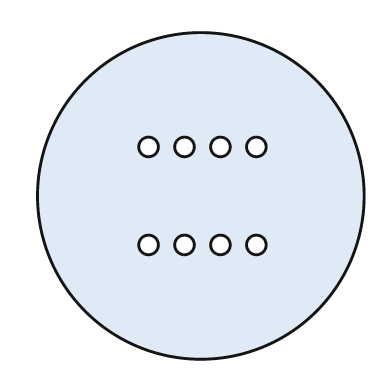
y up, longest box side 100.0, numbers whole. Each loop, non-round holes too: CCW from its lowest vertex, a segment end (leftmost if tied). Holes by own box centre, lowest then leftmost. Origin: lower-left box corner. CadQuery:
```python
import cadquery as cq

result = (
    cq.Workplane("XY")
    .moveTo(50.0, 50.0)
    .circle(50.0)
    .moveTo(34.0, 35.0)
    .circle(3.0)
    .moveTo(45.0, 35.0)
    .circle(3.0)
    .moveTo(56.0, 35.0)
    .circle(3.0)
    .moveTo(67.0, 35.0)
    .circle(3.0)
    .moveTo(34.0, 65.0)
    .circle(3.0)
    .moveTo(45.0, 65.0)
    .circle(3.0)
    .moveTo(56.0, 65.0)
    .circle(3.0)
    .moveTo(67.0, 65.0)
    .circle(3.0)
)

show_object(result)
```